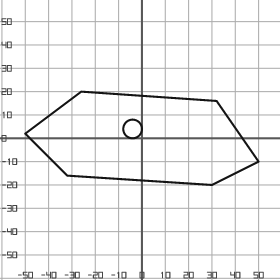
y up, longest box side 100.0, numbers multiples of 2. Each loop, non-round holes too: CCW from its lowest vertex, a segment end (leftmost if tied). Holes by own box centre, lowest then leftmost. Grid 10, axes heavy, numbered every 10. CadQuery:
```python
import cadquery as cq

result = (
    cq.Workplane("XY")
    .moveTo(30.0, -20.0)
    .lineTo(50.0, -10.0)
    .lineTo(32.0, 16.0)
    .lineTo(-26.0, 20.0)
    .lineTo(-50.0, 2.0)
    .lineTo(-32.0, -16.0)
    .close()
    .moveTo(-4.0, 4.0)
    .circle(4.0)
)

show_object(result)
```